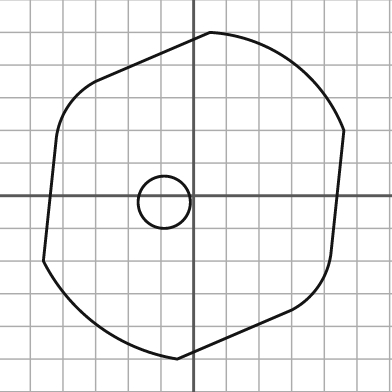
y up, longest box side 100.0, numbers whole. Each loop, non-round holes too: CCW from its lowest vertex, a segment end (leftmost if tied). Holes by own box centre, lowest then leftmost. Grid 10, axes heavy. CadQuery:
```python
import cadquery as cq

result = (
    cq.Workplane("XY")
    .moveTo(-5.0, -50.0)
    .lineTo(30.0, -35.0)
    .threePointArc((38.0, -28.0), (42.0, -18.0))
    .lineTo(46.0, 20.0)
    .threePointArc((30.0, 41.0), (5.0, 50.0))
    .lineTo(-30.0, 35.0)
    .threePointArc((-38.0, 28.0), (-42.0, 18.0))
    .lineTo(-46.0, -20.0)
    .threePointArc((-29.0, -40.0), (-5.0, -50.0))
    .close()
    .moveTo(-9.0, -2.0)
    .circle(8.0)
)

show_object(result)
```